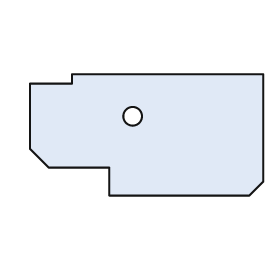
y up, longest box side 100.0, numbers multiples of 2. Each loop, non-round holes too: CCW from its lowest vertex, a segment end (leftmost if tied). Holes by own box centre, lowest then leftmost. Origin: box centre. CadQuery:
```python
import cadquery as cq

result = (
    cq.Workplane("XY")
    .moveTo(-16.0, -26.0)
    .lineTo(44.0, -26.0)
    .lineTo(50.0, -20.0)
    .lineTo(50.0, 26.0)
    .lineTo(-32.0, 26.0)
    .lineTo(-32.0, 22.0)
    .lineTo(-50.0, 22.0)
    .lineTo(-50.0, -6.0)
    .lineTo(-42.0, -14.0)
    .lineTo(-16.0, -14.0)
    .close()
    .moveTo(-6.0, 8.0)
    .circle(4.0)
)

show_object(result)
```